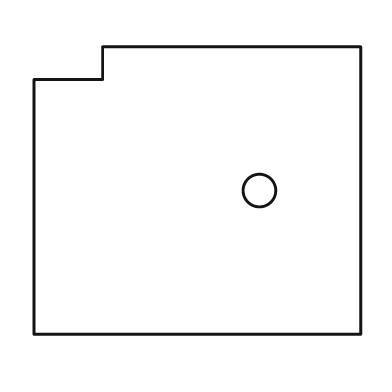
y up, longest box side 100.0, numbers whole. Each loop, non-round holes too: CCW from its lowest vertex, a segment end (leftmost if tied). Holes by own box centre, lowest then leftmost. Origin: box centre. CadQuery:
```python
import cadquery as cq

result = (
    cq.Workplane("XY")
    .moveTo(-50.0, -44.0)
    .lineTo(50.0, -44.0)
    .lineTo(50.0, 44.0)
    .lineTo(-29.0, 44.0)
    .lineTo(-29.0, 34.0)
    .lineTo(-50.0, 34.0)
    .close()
    .moveTo(19.0, 0.0)
    .circle(5.0)
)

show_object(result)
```